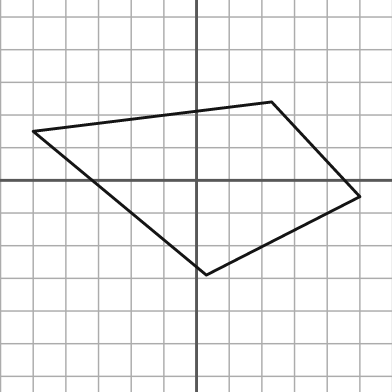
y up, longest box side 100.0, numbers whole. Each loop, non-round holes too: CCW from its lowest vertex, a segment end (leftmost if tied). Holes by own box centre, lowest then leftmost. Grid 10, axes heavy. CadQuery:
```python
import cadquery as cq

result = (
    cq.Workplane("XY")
    .moveTo(3.0, -29.0)
    .lineTo(50.0, -5.0)
    .lineTo(23.0, 24.0)
    .lineTo(-50.0, 15.0)
    .close()
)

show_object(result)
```